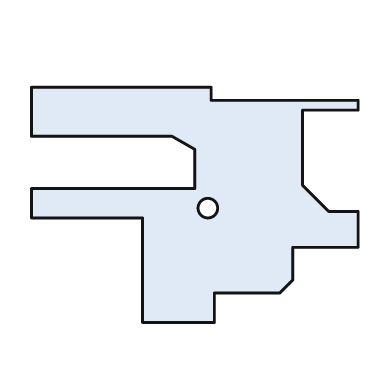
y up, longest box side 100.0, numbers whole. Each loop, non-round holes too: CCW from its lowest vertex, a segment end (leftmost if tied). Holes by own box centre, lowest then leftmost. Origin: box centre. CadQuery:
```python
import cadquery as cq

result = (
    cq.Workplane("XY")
    .moveTo(-16.0, -36.0)
    .lineTo(6.0, -36.0)
    .lineTo(6.0, -27.0)
    .lineTo(26.0, -27.0)
    .lineTo(30.0, -23.0)
    .lineTo(30.0, -13.0)
    .lineTo(50.0, -13.0)
    .lineTo(50.0, -2.0)
    .lineTo(41.0, -2.0)
    .lineTo(33.0, 6.0)
    .lineTo(33.0, 29.0)
    .lineTo(50.0, 29.0)
    .lineTo(50.0, 32.0)
    .lineTo(5.0, 32.0)
    .lineTo(5.0, 36.0)
    .lineTo(-50.0, 36.0)
    .lineTo(-50.0, 21.0)
    .lineTo(-7.0, 21.0)
    .lineTo(0.0, 17.0)
    .lineTo(0.0, 5.0)
    .lineTo(-50.0, 5.0)
    .lineTo(-50.0, -4.0)
    .lineTo(-16.0, -4.0)
    .close()
    .moveTo(4.0, -1.0)
    .circle(3.0)
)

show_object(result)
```